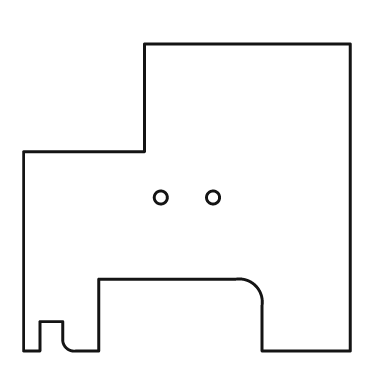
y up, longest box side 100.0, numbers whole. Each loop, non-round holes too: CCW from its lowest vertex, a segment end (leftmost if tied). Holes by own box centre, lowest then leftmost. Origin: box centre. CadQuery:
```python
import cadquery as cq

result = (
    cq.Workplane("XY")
    .moveTo(-50.0, -47.0)
    .lineTo(-45.0, -47.0)
    .lineTo(-45.0, -38.0)
    .lineTo(-38.0, -38.0)
    .lineTo(-38.0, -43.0)
    .threePointArc((-37.0, -46.0), (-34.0, -47.0))
    .lineTo(-27.0, -47.0)
    .lineTo(-27.0, -25.0)
    .lineTo(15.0, -25.0)
    .threePointArc((21.0, -27.0), (23.0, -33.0))
    .lineTo(23.0, -47.0)
    .lineTo(50.0, -47.0)
    .lineTo(50.0, 47.0)
    .lineTo(-13.0, 47.0)
    .lineTo(-13.0, 14.0)
    .lineTo(-50.0, 14.0)
    .close()
    .moveTo(-8.0, 0.0)
    .circle(2.0)
    .moveTo(8.0, 0.0)
    .circle(2.0)
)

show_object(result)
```